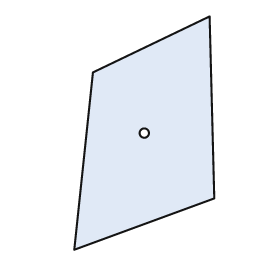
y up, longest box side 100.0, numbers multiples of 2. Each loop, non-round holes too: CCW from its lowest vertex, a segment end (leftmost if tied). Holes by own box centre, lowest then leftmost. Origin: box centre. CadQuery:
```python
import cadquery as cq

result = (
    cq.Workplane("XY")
    .moveTo(-30.0, -50.0)
    .lineTo(30.0, -28.0)
    .lineTo(28.0, 50.0)
    .lineTo(-22.0, 26.0)
    .close()
    .moveTo(0.0, 0.0)
    .circle(2.0)
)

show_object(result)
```